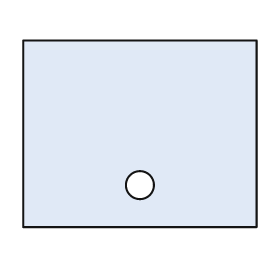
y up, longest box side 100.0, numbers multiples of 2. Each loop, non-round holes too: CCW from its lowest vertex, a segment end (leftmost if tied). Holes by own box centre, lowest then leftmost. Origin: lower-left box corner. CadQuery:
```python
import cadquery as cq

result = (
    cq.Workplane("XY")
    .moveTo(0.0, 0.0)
    .lineTo(100.0, 0.0)
    .lineTo(100.0, 80.0)
    .lineTo(0.0, 80.0)
    .close()
    .moveTo(50.0, 18.0)
    .circle(6.0)
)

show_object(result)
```